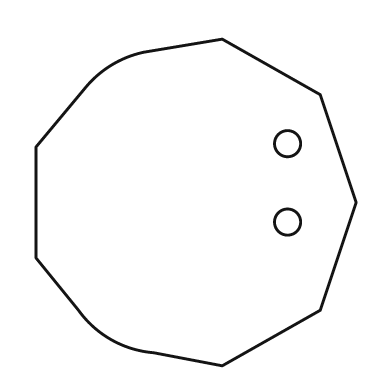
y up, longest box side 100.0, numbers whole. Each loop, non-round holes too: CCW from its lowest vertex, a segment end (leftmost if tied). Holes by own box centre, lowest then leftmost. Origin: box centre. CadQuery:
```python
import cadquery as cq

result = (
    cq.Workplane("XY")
    .moveTo(8.0, -50.0)
    .lineTo(38.0, -33.0)
    .lineTo(49.0, 0.0)
    .lineTo(38.0, 33.0)
    .lineTo(8.0, 50.0)
    .lineTo(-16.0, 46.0)
    .threePointArc((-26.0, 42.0), (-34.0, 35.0))
    .lineTo(-49.0, 17.0)
    .lineTo(-49.0, -17.0)
    .lineTo(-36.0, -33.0)
    .threePointArc((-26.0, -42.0), (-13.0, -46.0))
    .close()
    .moveTo(28.0, -6.0)
    .circle(4.0)
    .moveTo(28.0, 18.0)
    .circle(4.0)
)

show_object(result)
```